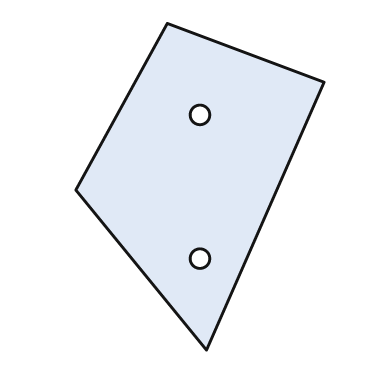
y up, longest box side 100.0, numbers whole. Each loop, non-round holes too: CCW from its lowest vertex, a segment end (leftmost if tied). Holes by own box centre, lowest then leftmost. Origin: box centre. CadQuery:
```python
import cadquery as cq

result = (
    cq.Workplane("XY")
    .moveTo(2.0, -50.0)
    .lineTo(38.0, 32.0)
    .lineTo(-10.0, 50.0)
    .lineTo(-38.0, -1.0)
    .close()
    .moveTo(0.0, -22.0)
    .circle(3.0)
    .moveTo(0.0, 22.0)
    .circle(3.0)
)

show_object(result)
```